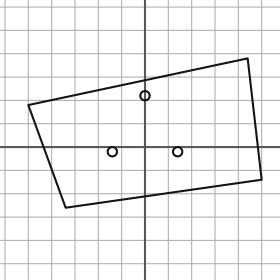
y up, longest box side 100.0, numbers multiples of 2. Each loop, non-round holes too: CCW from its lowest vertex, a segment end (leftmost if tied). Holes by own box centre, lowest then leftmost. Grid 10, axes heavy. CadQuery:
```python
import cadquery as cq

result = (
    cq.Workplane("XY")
    .moveTo(-34.0, -26.0)
    .lineTo(50.0, -14.0)
    .lineTo(44.0, 38.0)
    .lineTo(-50.0, 18.0)
    .close()
    .moveTo(-14.0, -2.0)
    .circle(2.0)
    .moveTo(14.0, -2.0)
    .circle(2.0)
    .moveTo(0.0, 22.0)
    .circle(2.0)
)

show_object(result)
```